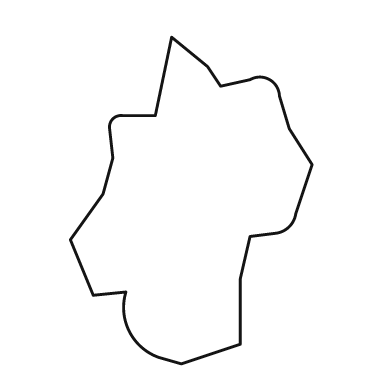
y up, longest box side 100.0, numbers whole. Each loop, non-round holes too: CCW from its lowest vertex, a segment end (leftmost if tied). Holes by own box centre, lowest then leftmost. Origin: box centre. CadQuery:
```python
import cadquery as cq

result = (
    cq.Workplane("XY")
    .moveTo(-3.0, -50.0)
    .lineTo(15.0, -44.0)
    .lineTo(15.0, -24.0)
    .lineTo(18.0, -11.0)
    .lineTo(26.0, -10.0)
    .threePointArc((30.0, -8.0), (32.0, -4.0))
    .lineTo(37.0, 11.0)
    .lineTo(30.0, 22.0)
    .lineTo(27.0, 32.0)
    .threePointArc((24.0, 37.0), (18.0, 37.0))
    .lineTo(9.0, 35.0)
    .lineTo(5.0, 41.0)
    .lineTo(-6.0, 50.0)
    .lineTo(-11.0, 26.0)
    .lineTo(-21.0, 26.0)
    .threePointArc((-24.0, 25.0), (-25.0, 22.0))
    .lineTo(-24.0, 13.0)
    .lineTo(-27.0, 2.0)
    .lineTo(-37.0, -12.0)
    .lineTo(-30.0, -29.0)
    .lineTo(-20.0, -28.0)
    .threePointArc((-19.0, -40.0), (-10.0, -48.0))
    .close()
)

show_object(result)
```